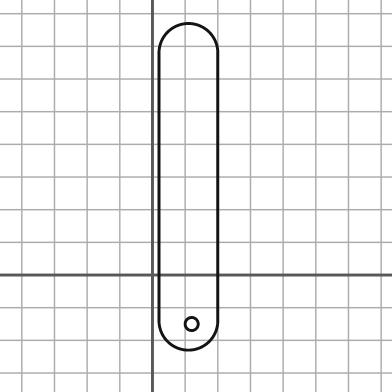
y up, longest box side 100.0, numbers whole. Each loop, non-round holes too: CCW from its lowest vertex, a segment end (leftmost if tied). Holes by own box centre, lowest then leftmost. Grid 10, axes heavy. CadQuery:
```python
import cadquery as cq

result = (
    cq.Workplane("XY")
    .moveTo(2.0, -14.0)
    .threePointArc((11.0, -23.0), (20.0, -14.0))
    .lineTo(20.0, 68.0)
    .threePointArc((11.0, 77.0), (2.0, 68.0))
    .close()
    .moveTo(12.0, -15.0)
    .circle(2.0)
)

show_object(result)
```